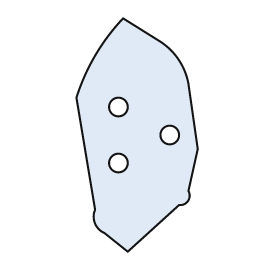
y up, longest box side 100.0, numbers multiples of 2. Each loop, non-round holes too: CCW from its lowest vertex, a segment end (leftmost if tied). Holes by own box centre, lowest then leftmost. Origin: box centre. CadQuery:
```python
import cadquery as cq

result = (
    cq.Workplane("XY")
    .moveTo(-4.0, -50.0)
    .lineTo(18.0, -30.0)
    .threePointArc((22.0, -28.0), (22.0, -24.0))
    .lineTo(26.0, -6.0)
    .lineTo(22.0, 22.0)
    .threePointArc((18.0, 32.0), (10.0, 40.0))
    .lineTo(-6.0, 50.0)
    .threePointArc((-18.0, 34.0), (-26.0, 16.0))
    .lineTo(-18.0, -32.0)
    .threePointArc((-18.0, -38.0), (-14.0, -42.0))
    .close()
    .moveTo(-8.0, -12.0)
    .circle(4.0)
    .moveTo(14.0, 0.0)
    .circle(4.0)
    .moveTo(-8.0, 12.0)
    .circle(4.0)
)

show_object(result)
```